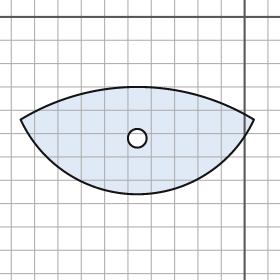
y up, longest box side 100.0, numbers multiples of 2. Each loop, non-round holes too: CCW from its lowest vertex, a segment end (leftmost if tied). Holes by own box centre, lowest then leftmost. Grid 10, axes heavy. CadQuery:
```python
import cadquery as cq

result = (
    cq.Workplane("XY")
    .moveTo(-96.0, -44.0)
    .threePointArc((-46.0, -76.0), (4.0, -44.0))
    .threePointArc((-46.0, -30.0), (-96.0, -44.0))
    .close()
    .moveTo(-46.0, -52.0)
    .circle(4.0)
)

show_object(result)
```